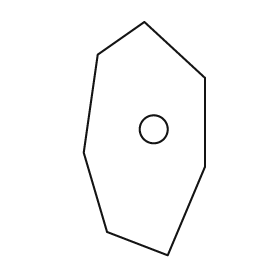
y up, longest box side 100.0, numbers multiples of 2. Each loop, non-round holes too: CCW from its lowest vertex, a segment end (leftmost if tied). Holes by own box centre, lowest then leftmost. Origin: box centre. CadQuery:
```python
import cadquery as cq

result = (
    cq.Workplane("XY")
    .moveTo(10.0, -50.0)
    .lineTo(26.0, -12.0)
    .lineTo(26.0, 26.0)
    .lineTo(0.0, 50.0)
    .lineTo(-20.0, 36.0)
    .lineTo(-26.0, -6.0)
    .lineTo(-16.0, -40.0)
    .close()
    .moveTo(4.0, 4.0)
    .circle(6.0)
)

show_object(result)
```